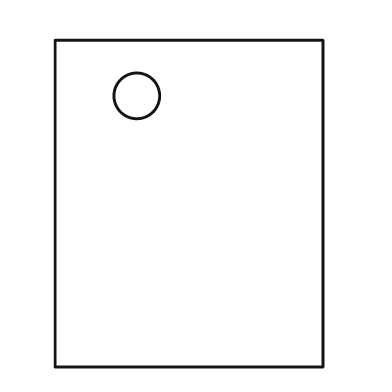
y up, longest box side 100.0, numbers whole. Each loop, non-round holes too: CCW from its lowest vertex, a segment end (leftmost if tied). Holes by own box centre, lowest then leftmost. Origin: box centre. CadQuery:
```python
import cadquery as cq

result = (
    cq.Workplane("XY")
    .moveTo(-41.0, -50.0)
    .lineTo(41.0, -50.0)
    .lineTo(41.0, 50.0)
    .lineTo(-41.0, 50.0)
    .close()
    .moveTo(-16.0, 33.0)
    .circle(7.0)
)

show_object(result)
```